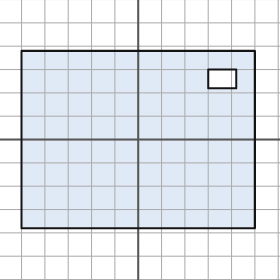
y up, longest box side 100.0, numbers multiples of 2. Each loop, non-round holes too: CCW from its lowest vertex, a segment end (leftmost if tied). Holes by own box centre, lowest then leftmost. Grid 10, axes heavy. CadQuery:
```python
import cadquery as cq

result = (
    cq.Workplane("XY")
    .moveTo(-50.0, -38.0)
    .lineTo(50.0, -38.0)
    .lineTo(50.0, 38.0)
    .lineTo(-50.0, 38.0)
    .close()
    .moveTo(30.0, 22.0)
    .lineTo(42.0, 22.0)
    .lineTo(42.0, 30.0)
    .lineTo(30.0, 30.0)
    .close()
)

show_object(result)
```